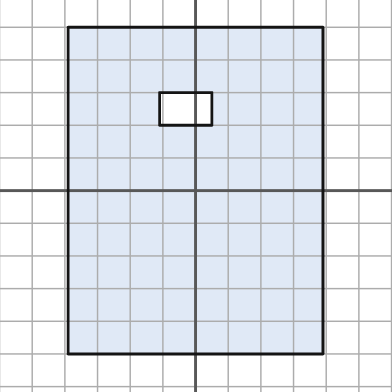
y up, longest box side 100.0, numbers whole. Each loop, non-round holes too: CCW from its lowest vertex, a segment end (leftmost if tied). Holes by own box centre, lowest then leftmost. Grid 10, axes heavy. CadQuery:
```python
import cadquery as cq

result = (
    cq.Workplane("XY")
    .moveTo(-39.0, -50.0)
    .lineTo(39.0, -50.0)
    .lineTo(39.0, 50.0)
    .lineTo(-39.0, 50.0)
    .close()
    .moveTo(-11.0, 20.0)
    .lineTo(5.0, 20.0)
    .lineTo(5.0, 30.0)
    .lineTo(-11.0, 30.0)
    .close()
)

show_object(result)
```